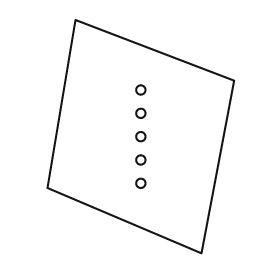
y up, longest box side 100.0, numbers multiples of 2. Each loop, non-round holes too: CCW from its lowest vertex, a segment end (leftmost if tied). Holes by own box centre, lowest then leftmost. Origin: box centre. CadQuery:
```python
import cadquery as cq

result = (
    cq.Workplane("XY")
    .moveTo(26.0, -50.0)
    .lineTo(40.0, 24.0)
    .lineTo(-28.0, 50.0)
    .lineTo(-40.0, -22.0)
    .close()
    .moveTo(0.0, -20.0)
    .circle(2.0)
    .moveTo(0.0, -10.0)
    .circle(2.0)
    .moveTo(0.0, 0.0)
    .circle(2.0)
    .moveTo(0.0, 10.0)
    .circle(2.0)
    .moveTo(0.0, 20.0)
    .circle(2.0)
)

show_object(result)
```